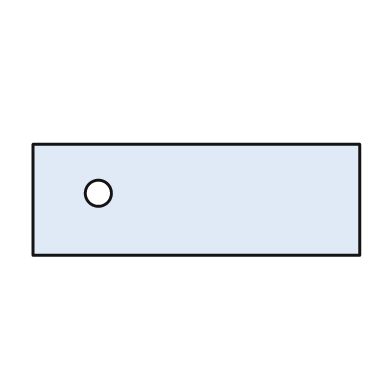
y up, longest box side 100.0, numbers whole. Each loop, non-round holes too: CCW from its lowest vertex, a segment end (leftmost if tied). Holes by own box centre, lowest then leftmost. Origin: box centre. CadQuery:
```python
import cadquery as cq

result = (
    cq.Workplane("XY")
    .moveTo(-50.0, -17.0)
    .lineTo(50.0, -17.0)
    .lineTo(50.0, 17.0)
    .lineTo(-50.0, 17.0)
    .close()
    .moveTo(-30.0, 2.0)
    .circle(4.0)
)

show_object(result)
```